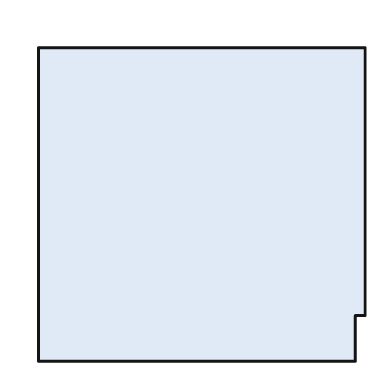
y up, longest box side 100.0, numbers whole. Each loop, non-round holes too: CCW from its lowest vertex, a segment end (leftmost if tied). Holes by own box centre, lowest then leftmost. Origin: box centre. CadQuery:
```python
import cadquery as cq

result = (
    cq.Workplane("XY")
    .moveTo(-50.0, -48.0)
    .lineTo(47.0, -48.0)
    .lineTo(47.0, -34.0)
    .lineTo(50.0, -34.0)
    .lineTo(50.0, 48.0)
    .lineTo(-50.0, 48.0)
    .close()
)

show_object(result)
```